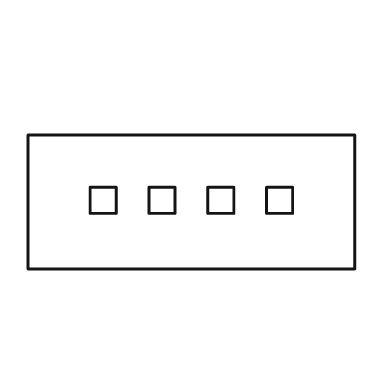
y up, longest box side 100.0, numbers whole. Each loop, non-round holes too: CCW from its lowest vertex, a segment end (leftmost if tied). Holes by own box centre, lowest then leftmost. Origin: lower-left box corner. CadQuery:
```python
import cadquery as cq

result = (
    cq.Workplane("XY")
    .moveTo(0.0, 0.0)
    .lineTo(100.0, 0.0)
    .lineTo(100.0, 41.0)
    .lineTo(0.0, 41.0)
    .close()
    .moveTo(19.0, 17.0)
    .lineTo(27.0, 17.0)
    .lineTo(27.0, 25.0)
    .lineTo(19.0, 25.0)
    .close()
    .moveTo(37.0, 17.0)
    .lineTo(45.0, 17.0)
    .lineTo(45.0, 25.0)
    .lineTo(37.0, 25.0)
    .close()
    .moveTo(55.0, 17.0)
    .lineTo(63.0, 17.0)
    .lineTo(63.0, 25.0)
    .lineTo(55.0, 25.0)
    .close()
    .moveTo(73.0, 17.0)
    .lineTo(81.0, 17.0)
    .lineTo(81.0, 25.0)
    .lineTo(73.0, 25.0)
    .close()
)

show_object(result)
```